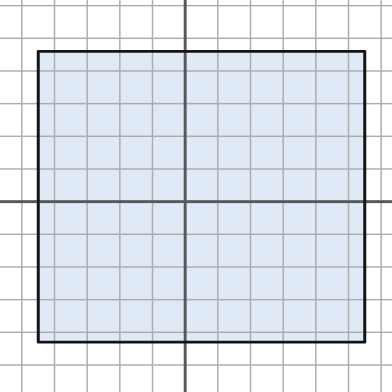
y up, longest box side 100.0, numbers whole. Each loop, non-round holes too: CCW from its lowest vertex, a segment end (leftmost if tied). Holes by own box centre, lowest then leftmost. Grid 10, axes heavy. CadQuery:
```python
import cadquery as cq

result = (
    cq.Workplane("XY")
    .moveTo(-45.0, -43.0)
    .lineTo(55.0, -43.0)
    .lineTo(55.0, 46.0)
    .lineTo(-45.0, 46.0)
    .close()
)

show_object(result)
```